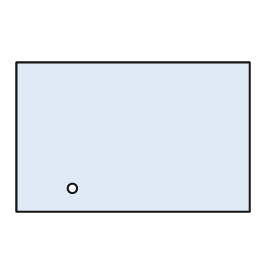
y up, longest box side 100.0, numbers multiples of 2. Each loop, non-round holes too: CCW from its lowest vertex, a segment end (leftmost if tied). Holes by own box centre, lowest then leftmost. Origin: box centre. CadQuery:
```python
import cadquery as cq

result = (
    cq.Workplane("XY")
    .moveTo(-50.0, -32.0)
    .lineTo(50.0, -32.0)
    .lineTo(50.0, 32.0)
    .lineTo(-50.0, 32.0)
    .close()
    .moveTo(-26.0, -22.0)
    .circle(2.0)
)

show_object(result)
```